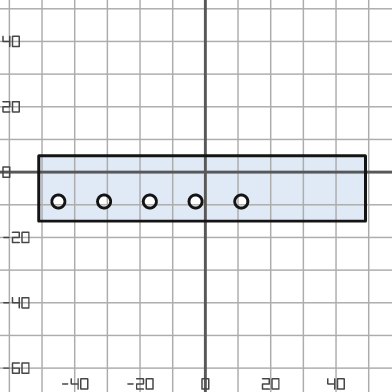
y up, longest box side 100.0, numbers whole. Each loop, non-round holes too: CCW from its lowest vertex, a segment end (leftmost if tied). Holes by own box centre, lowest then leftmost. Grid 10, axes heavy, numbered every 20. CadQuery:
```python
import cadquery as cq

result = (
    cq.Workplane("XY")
    .moveTo(-51.0, -15.0)
    .lineTo(49.0, -15.0)
    .lineTo(49.0, 5.0)
    .lineTo(-51.0, 5.0)
    .close()
    .moveTo(-45.0, -9.0)
    .circle(2.0)
    .moveTo(-31.0, -9.0)
    .circle(2.0)
    .moveTo(-17.0, -9.0)
    .circle(2.0)
    .moveTo(-3.0, -9.0)
    .circle(2.0)
    .moveTo(11.0, -9.0)
    .circle(2.0)
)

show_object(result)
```